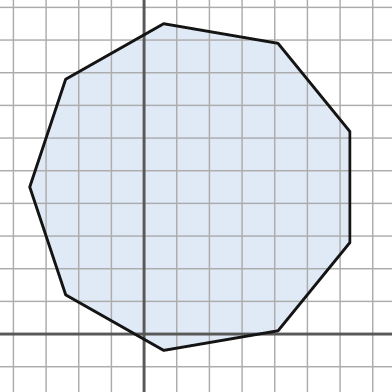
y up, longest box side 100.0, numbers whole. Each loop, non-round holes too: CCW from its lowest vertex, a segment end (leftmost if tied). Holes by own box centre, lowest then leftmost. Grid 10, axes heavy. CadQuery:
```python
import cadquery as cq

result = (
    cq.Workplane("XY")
    .moveTo(6.0, -5.0)
    .lineTo(41.0, 1.0)
    .lineTo(63.0, 28.0)
    .lineTo(63.0, 62.0)
    .lineTo(41.0, 89.0)
    .lineTo(6.0, 95.0)
    .lineTo(-24.0, 78.0)
    .lineTo(-35.0, 45.0)
    .lineTo(-24.0, 12.0)
    .close()
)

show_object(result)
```